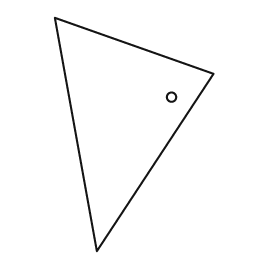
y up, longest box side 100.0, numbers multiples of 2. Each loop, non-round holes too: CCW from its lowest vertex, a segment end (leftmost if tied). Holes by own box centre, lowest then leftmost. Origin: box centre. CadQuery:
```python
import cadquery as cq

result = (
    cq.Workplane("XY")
    .moveTo(-16.0, -50.0)
    .lineTo(34.0, 26.0)
    .lineTo(-34.0, 50.0)
    .close()
    .moveTo(16.0, 16.0)
    .circle(2.0)
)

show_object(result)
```